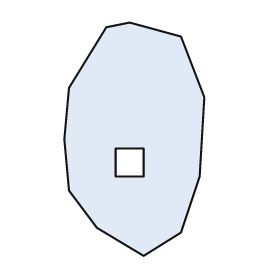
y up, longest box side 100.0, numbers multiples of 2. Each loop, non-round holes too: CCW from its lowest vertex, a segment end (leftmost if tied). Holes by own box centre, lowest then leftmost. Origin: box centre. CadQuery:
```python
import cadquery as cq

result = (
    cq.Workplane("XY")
    .moveTo(4.0, -50.0)
    .lineTo(20.0, -40.0)
    .lineTo(28.0, -16.0)
    .lineTo(30.0, 18.0)
    .lineTo(20.0, 44.0)
    .lineTo(-2.0, 50.0)
    .lineTo(-12.0, 48.0)
    .lineTo(-28.0, 22.0)
    .lineTo(-30.0, 0.0)
    .lineTo(-28.0, -22.0)
    .lineTo(-16.0, -38.0)
    .close()
    .moveTo(-8.0, -16.0)
    .lineTo(4.0, -16.0)
    .lineTo(4.0, -4.0)
    .lineTo(-8.0, -4.0)
    .close()
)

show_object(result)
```